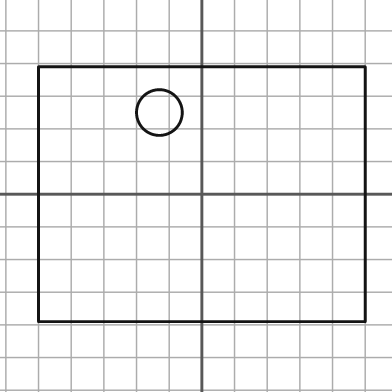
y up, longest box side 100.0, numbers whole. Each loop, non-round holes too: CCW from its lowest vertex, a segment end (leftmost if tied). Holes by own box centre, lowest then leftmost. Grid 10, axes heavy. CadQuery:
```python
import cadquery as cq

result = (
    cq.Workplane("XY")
    .moveTo(-50.0, -39.0)
    .lineTo(50.0, -39.0)
    .lineTo(50.0, 39.0)
    .lineTo(-50.0, 39.0)
    .close()
    .moveTo(-13.0, 25.0)
    .circle(7.0)
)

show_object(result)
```